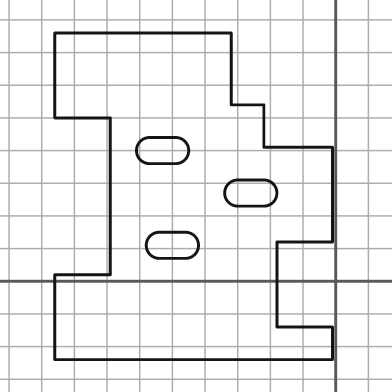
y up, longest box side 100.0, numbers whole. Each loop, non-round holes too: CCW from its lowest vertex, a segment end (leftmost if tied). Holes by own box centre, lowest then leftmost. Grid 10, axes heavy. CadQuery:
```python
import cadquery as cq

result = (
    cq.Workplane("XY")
    .moveTo(-86.0, -24.0)
    .lineTo(-1.0, -24.0)
    .lineTo(-1.0, -14.0)
    .lineTo(-18.0, -14.0)
    .lineTo(-18.0, 12.0)
    .lineTo(-1.0, 12.0)
    .lineTo(-1.0, 41.0)
    .lineTo(-22.0, 41.0)
    .lineTo(-22.0, 54.0)
    .lineTo(-32.0, 54.0)
    .lineTo(-32.0, 76.0)
    .lineTo(-86.0, 76.0)
    .lineTo(-86.0, 50.0)
    .lineTo(-69.0, 50.0)
    .lineTo(-69.0, 2.0)
    .lineTo(-86.0, 2.0)
    .close()
    .moveTo(-54.0, 7.0)
    .lineTo(-46.0, 7.0)
    .threePointArc((-42.0, 11.0), (-46.0, 15.0))
    .lineTo(-54.0, 15.0)
    .threePointArc((-58.0, 11.0), (-54.0, 7.0))
    .close()
    .moveTo(-30.0, 23.0)
    .lineTo(-22.0, 23.0)
    .threePointArc((-18.0, 27.0), (-22.0, 31.0))
    .lineTo(-30.0, 31.0)
    .threePointArc((-34.0, 27.0), (-30.0, 23.0))
    .close()
    .moveTo(-57.0, 36.0)
    .lineTo(-49.0, 36.0)
    .threePointArc((-45.0, 40.0), (-49.0, 44.0))
    .lineTo(-57.0, 44.0)
    .threePointArc((-61.0, 40.0), (-57.0, 36.0))
    .close()
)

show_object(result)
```